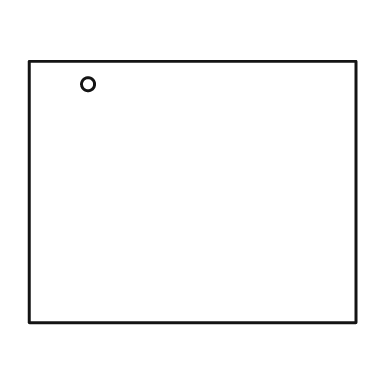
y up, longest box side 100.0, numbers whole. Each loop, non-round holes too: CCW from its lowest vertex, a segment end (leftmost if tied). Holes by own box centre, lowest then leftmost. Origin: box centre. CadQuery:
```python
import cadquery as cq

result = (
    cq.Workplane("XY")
    .moveTo(-50.0, -40.0)
    .lineTo(50.0, -40.0)
    .lineTo(50.0, 40.0)
    .lineTo(-50.0, 40.0)
    .close()
    .moveTo(-32.0, 33.0)
    .circle(2.0)
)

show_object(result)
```